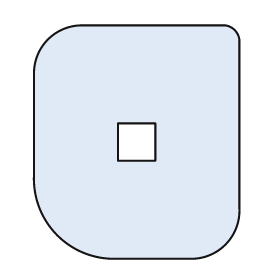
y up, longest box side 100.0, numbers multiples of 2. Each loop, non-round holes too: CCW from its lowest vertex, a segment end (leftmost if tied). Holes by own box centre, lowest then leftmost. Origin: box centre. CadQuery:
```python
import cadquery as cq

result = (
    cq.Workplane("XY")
    .moveTo(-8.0, -50.0)
    .lineTo(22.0, -50.0)
    .threePointArc((38.0, -44.0), (44.0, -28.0))
    .lineTo(44.0, 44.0)
    .threePointArc((42.0, 48.0), (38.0, 50.0))
    .lineTo(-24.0, 50.0)
    .threePointArc((-38.0, 44.0), (-44.0, 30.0))
    .lineTo(-44.0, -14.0)
    .threePointArc((-34.0, -40.0), (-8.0, -50.0))
    .close()
    .moveTo(-8.0, -8.0)
    .lineTo(8.0, -8.0)
    .lineTo(8.0, 8.0)
    .lineTo(-8.0, 8.0)
    .close()
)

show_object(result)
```